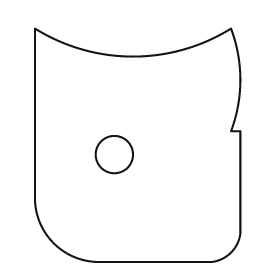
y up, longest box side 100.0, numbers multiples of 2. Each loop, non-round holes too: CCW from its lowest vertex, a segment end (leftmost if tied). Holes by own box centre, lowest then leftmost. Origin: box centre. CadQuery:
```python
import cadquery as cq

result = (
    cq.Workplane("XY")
    .moveTo(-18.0, -50.0)
    .lineTo(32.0, -50.0)
    .threePointArc((40.0, -46.0), (44.0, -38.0))
    .lineTo(44.0, 6.0)
    .lineTo(40.0, 6.0)
    .threePointArc((44.0, 28.0), (40.0, 50.0))
    .threePointArc((-2.0, 38.0), (-44.0, 50.0))
    .lineTo(-44.0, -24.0)
    .threePointArc((-36.0, -42.0), (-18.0, -50.0))
    .close()
    .moveTo(-10.0, -4.0)
    .circle(8.0)
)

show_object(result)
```